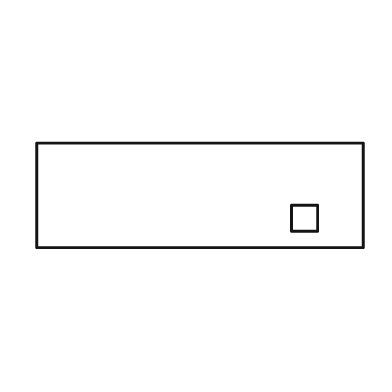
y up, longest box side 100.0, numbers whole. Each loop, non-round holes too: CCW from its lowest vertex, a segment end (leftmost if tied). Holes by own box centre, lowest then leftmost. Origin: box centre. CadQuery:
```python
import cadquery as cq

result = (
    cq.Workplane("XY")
    .moveTo(-50.0, -16.0)
    .lineTo(50.0, -16.0)
    .lineTo(50.0, 16.0)
    .lineTo(-50.0, 16.0)
    .close()
    .moveTo(28.0, -11.0)
    .lineTo(36.0, -11.0)
    .lineTo(36.0, -3.0)
    .lineTo(28.0, -3.0)
    .close()
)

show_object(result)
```